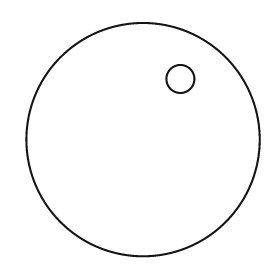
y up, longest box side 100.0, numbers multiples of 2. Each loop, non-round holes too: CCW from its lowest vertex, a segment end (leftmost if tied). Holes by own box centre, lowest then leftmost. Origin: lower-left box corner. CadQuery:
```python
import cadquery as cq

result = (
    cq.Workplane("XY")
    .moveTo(50.0, 50.0)
    .circle(50.0)
    .moveTo(66.0, 76.0)
    .circle(6.0)
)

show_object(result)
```